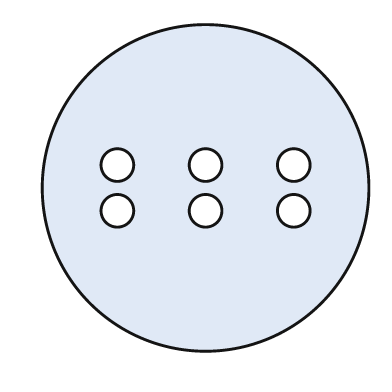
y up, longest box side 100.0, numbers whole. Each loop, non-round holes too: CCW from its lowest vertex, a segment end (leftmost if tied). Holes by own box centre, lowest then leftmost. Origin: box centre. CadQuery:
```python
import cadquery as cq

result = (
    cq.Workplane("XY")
    .moveTo(0.0, 0.0)
    .circle(50.0)
    .moveTo(-27.0, -7.0)
    .circle(5.0)
    .moveTo(0.0, -7.0)
    .circle(5.0)
    .moveTo(27.0, -7.0)
    .circle(5.0)
    .moveTo(-27.0, 7.0)
    .circle(5.0)
    .moveTo(0.0, 7.0)
    .circle(5.0)
    .moveTo(27.0, 7.0)
    .circle(5.0)
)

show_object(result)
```